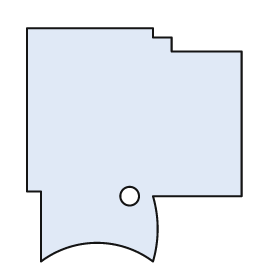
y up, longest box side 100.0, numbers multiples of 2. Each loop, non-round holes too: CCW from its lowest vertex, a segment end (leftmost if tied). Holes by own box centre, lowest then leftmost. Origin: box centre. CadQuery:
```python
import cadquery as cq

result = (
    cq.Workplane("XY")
    .moveTo(-40.0, -50.0)
    .threePointArc((-16.0, -42.0), (8.0, -50.0))
    .threePointArc((10.0, -36.0), (8.0, -22.0))
    .lineTo(46.0, -22.0)
    .lineTo(46.0, 40.0)
    .lineTo(16.0, 40.0)
    .lineTo(16.0, 46.0)
    .lineTo(8.0, 46.0)
    .lineTo(8.0, 50.0)
    .lineTo(-46.0, 50.0)
    .lineTo(-46.0, -20.0)
    .lineTo(-40.0, -20.0)
    .close()
    .moveTo(-2.0, -22.0)
    .circle(4.0)
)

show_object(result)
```